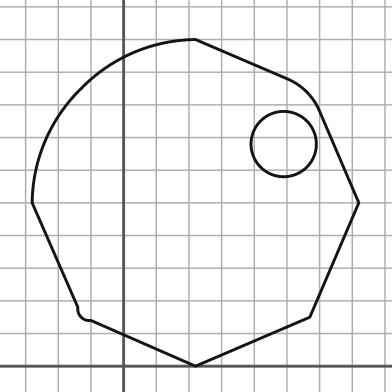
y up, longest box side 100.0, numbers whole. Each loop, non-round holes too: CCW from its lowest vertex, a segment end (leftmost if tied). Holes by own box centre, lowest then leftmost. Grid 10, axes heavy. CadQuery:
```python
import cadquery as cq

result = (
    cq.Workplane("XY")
    .moveTo(22.0, 0.0)
    .lineTo(57.0, 15.0)
    .lineTo(72.0, 50.0)
    .lineTo(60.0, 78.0)
    .threePointArc((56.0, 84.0), (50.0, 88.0))
    .lineTo(22.0, 100.0)
    .threePointArc((3.0, 96.0), (-13.0, 85.0))
    .threePointArc((-24.0, 69.0), (-28.0, 50.0))
    .lineTo(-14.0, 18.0)
    .threePointArc((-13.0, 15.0), (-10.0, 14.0))
    .close()
    .moveTo(49.0, 68.0)
    .circle(10.0)
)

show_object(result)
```